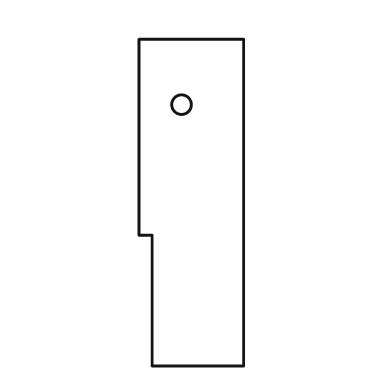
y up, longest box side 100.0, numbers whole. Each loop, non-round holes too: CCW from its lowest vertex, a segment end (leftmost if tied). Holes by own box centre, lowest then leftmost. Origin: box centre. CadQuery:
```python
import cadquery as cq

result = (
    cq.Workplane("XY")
    .moveTo(-12.0, -50.0)
    .lineTo(16.0, -50.0)
    .lineTo(16.0, 50.0)
    .lineTo(-16.0, 50.0)
    .lineTo(-16.0, -10.0)
    .lineTo(-12.0, -10.0)
    .close()
    .moveTo(-3.0, 30.0)
    .circle(3.0)
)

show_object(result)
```